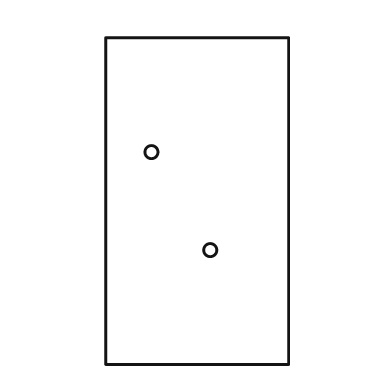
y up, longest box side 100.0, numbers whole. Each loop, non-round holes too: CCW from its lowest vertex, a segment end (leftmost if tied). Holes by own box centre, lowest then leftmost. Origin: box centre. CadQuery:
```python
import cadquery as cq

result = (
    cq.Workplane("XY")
    .moveTo(-28.0, -50.0)
    .lineTo(28.0, -50.0)
    .lineTo(28.0, 50.0)
    .lineTo(-28.0, 50.0)
    .close()
    .moveTo(4.0, -15.0)
    .circle(2.0)
    .moveTo(-14.0, 15.0)
    .circle(2.0)
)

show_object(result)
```